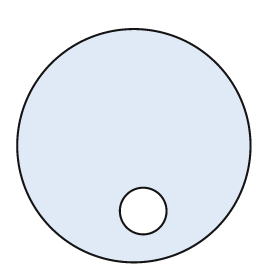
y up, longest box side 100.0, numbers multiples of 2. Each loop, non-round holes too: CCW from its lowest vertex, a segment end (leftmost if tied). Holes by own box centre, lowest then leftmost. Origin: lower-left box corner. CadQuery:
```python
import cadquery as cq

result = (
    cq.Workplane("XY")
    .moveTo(50.0, 50.0)
    .circle(50.0)
    .moveTo(54.0, 22.0)
    .circle(10.0)
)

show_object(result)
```